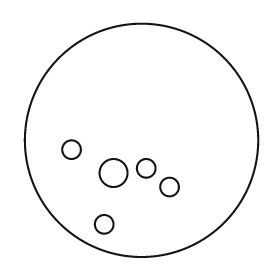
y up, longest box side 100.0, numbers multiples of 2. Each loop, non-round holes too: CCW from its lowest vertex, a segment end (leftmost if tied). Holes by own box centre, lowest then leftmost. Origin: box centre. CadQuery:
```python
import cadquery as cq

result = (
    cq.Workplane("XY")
    .moveTo(0.0, 0.0)
    .circle(50.0)
    .moveTo(-16.0, -36.0)
    .circle(4.0)
    .moveTo(12.0, -20.0)
    .circle(4.0)
    .moveTo(-12.0, -14.0)
    .circle(6.0)
    .moveTo(2.0, -12.0)
    .circle(4.0)
    .moveTo(-30.0, -4.0)
    .circle(4.0)
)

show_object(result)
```